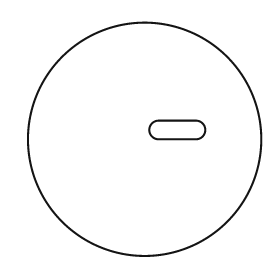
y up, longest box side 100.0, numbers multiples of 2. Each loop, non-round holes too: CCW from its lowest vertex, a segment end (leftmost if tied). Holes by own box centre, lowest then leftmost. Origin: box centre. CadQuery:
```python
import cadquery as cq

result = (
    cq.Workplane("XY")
    .moveTo(0.0, 0.0)
    .circle(50.0)
    .moveTo(6.0, 0.0)
    .lineTo(22.0, 0.0)
    .threePointArc((26.0, 4.0), (22.0, 8.0))
    .lineTo(6.0, 8.0)
    .threePointArc((2.0, 4.0), (6.0, 0.0))
    .close()
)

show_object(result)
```